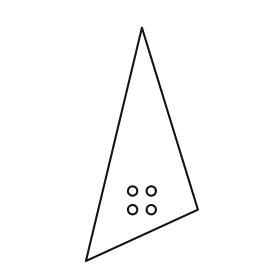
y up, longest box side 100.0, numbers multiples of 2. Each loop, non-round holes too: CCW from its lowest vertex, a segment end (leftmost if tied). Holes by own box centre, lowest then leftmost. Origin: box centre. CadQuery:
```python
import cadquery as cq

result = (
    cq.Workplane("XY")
    .moveTo(-24.0, -50.0)
    .lineTo(24.0, -28.0)
    .lineTo(0.0, 50.0)
    .close()
    .moveTo(-4.0, -28.0)
    .circle(2.0)
    .moveTo(4.0, -28.0)
    .circle(2.0)
    .moveTo(-4.0, -20.0)
    .circle(2.0)
    .moveTo(4.0, -20.0)
    .circle(2.0)
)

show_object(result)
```